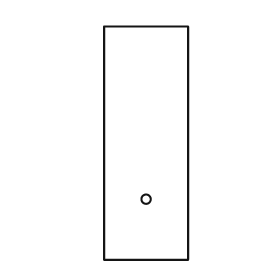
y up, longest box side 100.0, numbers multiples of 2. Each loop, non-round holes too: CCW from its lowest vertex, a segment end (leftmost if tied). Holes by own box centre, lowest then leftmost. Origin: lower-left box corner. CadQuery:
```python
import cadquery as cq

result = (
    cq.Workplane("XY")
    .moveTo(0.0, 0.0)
    .lineTo(36.0, 0.0)
    .lineTo(36.0, 100.0)
    .lineTo(0.0, 100.0)
    .close()
    .moveTo(18.0, 26.0)
    .circle(2.0)
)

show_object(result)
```